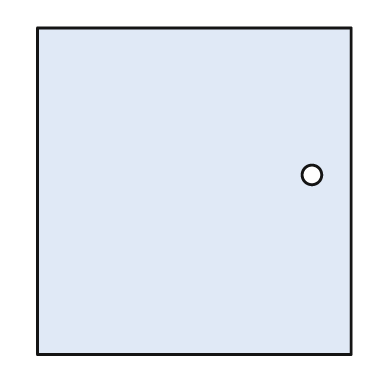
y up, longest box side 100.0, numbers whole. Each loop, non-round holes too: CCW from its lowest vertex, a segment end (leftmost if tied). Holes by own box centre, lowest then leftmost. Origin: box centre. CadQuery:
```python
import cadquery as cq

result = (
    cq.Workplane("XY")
    .moveTo(-48.0, -50.0)
    .lineTo(48.0, -50.0)
    .lineTo(48.0, 50.0)
    .lineTo(-48.0, 50.0)
    .close()
    .moveTo(36.0, 5.0)
    .circle(3.0)
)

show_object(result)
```